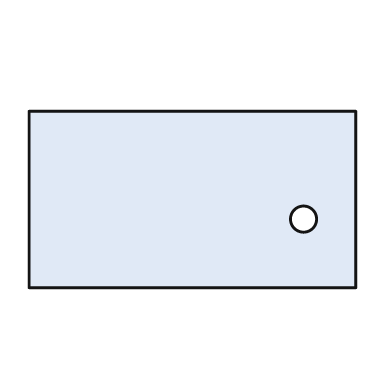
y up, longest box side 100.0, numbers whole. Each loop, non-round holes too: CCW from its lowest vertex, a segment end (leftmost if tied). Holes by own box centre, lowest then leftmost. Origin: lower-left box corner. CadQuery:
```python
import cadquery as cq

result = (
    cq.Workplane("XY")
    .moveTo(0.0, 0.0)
    .lineTo(100.0, 0.0)
    .lineTo(100.0, 54.0)
    .lineTo(0.0, 54.0)
    .close()
    .moveTo(84.0, 21.0)
    .circle(4.0)
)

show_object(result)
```